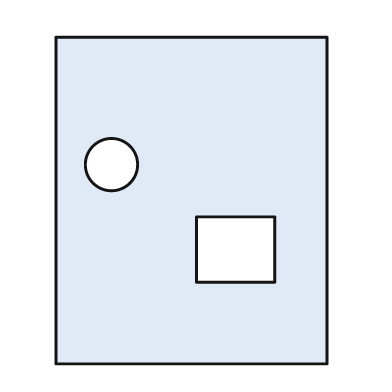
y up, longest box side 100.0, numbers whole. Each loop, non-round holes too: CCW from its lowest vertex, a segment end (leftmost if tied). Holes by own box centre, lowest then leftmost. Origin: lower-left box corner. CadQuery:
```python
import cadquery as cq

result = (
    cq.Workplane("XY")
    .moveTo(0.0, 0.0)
    .lineTo(83.0, 0.0)
    .lineTo(83.0, 100.0)
    .lineTo(0.0, 100.0)
    .close()
    .moveTo(43.0, 25.0)
    .lineTo(67.0, 25.0)
    .lineTo(67.0, 45.0)
    .lineTo(43.0, 45.0)
    .close()
    .moveTo(17.0, 61.0)
    .circle(8.0)
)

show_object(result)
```